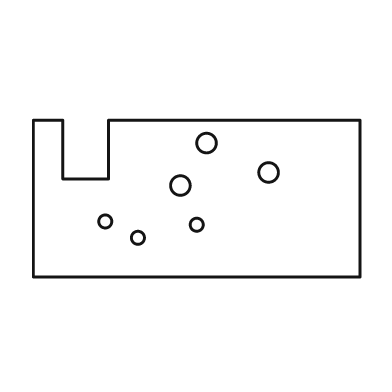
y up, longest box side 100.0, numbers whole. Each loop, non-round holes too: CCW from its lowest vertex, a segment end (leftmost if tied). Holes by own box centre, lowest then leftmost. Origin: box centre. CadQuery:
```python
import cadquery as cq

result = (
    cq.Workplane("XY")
    .moveTo(-50.0, -24.0)
    .lineTo(50.0, -24.0)
    .lineTo(50.0, 24.0)
    .lineTo(-27.0, 24.0)
    .lineTo(-27.0, 6.0)
    .lineTo(-41.0, 6.0)
    .lineTo(-41.0, 24.0)
    .lineTo(-50.0, 24.0)
    .close()
    .moveTo(-18.0, -12.0)
    .circle(2.0)
    .moveTo(0.0, -8.0)
    .circle(2.0)
    .moveTo(-28.0, -7.0)
    .circle(2.0)
    .moveTo(-5.0, 4.0)
    .circle(3.0)
    .moveTo(22.0, 8.0)
    .circle(3.0)
    .moveTo(3.0, 17.0)
    .circle(3.0)
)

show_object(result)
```